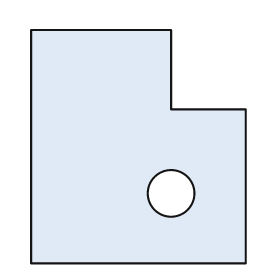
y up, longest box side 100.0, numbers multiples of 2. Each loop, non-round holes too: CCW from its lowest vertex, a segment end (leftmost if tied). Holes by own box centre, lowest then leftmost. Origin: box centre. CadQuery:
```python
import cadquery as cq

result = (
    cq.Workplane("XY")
    .moveTo(-46.0, -50.0)
    .lineTo(46.0, -50.0)
    .lineTo(46.0, 16.0)
    .lineTo(14.0, 16.0)
    .lineTo(14.0, 50.0)
    .lineTo(-46.0, 50.0)
    .close()
    .moveTo(14.0, -20.0)
    .circle(10.0)
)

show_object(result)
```